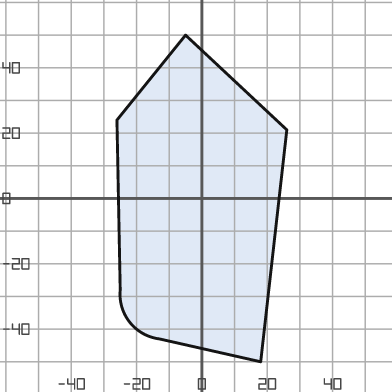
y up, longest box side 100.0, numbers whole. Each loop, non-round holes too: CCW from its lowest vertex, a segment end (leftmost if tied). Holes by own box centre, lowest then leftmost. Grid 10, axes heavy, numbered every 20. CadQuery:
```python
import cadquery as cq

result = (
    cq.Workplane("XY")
    .moveTo(18.0, -50.0)
    .lineTo(26.0, 21.0)
    .lineTo(-5.0, 50.0)
    .lineTo(-26.0, 24.0)
    .lineTo(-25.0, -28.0)
    .threePointArc((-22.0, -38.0), (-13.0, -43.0))
    .close()
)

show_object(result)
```